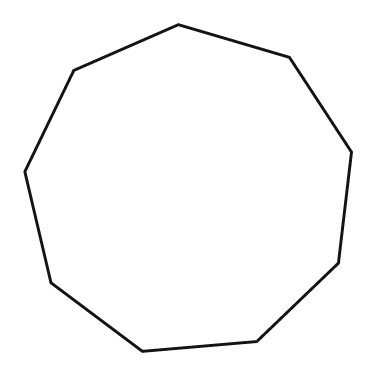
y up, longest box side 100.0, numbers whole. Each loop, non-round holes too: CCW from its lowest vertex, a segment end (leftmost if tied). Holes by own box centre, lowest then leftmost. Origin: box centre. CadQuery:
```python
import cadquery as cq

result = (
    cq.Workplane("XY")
    .moveTo(-14.0, -50.0)
    .lineTo(21.0, -47.0)
    .lineTo(46.0, -23.0)
    .lineTo(50.0, 11.0)
    .lineTo(31.0, 40.0)
    .lineTo(-3.0, 50.0)
    .lineTo(-35.0, 36.0)
    .lineTo(-50.0, 5.0)
    .lineTo(-42.0, -29.0)
    .close()
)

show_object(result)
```